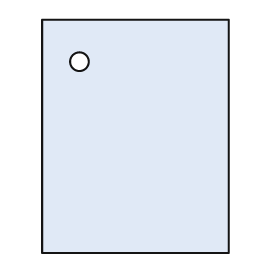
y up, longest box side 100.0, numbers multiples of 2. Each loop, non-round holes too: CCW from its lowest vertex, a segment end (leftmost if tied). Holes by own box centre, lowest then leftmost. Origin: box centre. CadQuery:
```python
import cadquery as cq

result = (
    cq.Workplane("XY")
    .moveTo(-40.0, -50.0)
    .lineTo(40.0, -50.0)
    .lineTo(40.0, 50.0)
    .lineTo(-40.0, 50.0)
    .close()
    .moveTo(-24.0, 32.0)
    .circle(4.0)
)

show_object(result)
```